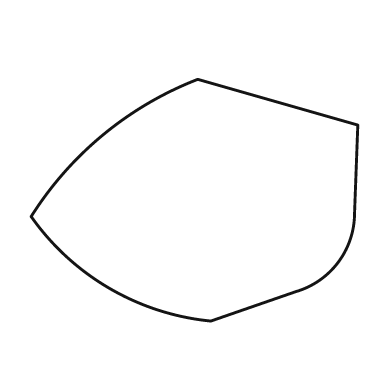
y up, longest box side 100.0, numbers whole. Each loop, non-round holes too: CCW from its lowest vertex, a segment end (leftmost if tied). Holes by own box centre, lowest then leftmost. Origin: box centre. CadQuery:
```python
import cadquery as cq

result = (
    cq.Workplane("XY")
    .moveTo(5.0, -37.0)
    .lineTo(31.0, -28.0)
    .threePointArc((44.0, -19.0), (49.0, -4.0))
    .lineTo(50.0, 23.0)
    .lineTo(1.0, 37.0)
    .threePointArc((-28.0, 20.0), (-50.0, -5.0))
    .threePointArc((-26.0, -27.0), (5.0, -37.0))
    .close()
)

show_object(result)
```